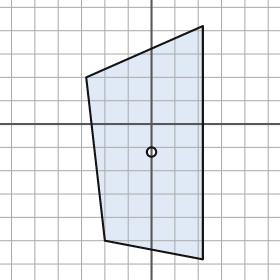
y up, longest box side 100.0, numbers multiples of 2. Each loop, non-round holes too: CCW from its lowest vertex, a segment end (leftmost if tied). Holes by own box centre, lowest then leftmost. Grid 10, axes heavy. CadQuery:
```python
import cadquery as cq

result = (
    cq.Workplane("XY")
    .moveTo(22.0, -58.0)
    .lineTo(22.0, 42.0)
    .lineTo(-28.0, 20.0)
    .lineTo(-20.0, -50.0)
    .close()
    .moveTo(0.0, -12.0)
    .circle(2.0)
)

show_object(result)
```